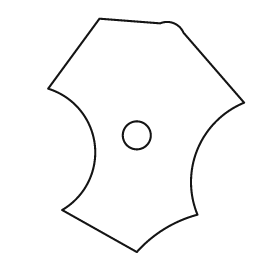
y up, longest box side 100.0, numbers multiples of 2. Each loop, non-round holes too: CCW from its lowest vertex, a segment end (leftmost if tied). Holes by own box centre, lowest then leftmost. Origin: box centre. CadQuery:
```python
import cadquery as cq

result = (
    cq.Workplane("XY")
    .moveTo(-4.0, -50.0)
    .threePointArc((8.0, -40.0), (22.0, -34.0))
    .threePointArc((22.0, -6.0), (42.0, 14.0))
    .lineTo(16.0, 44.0)
    .threePointArc((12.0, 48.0), (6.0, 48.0))
    .lineTo(-20.0, 50.0)
    .lineTo(-42.0, 20.0)
    .threePointArc((-22.0, -4.0), (-36.0, -32.0))
    .close()
    .moveTo(-4.0, 0.0)
    .circle(6.0)
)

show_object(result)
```